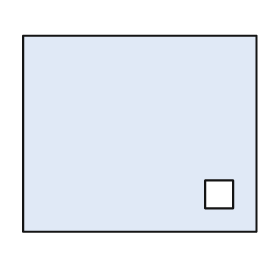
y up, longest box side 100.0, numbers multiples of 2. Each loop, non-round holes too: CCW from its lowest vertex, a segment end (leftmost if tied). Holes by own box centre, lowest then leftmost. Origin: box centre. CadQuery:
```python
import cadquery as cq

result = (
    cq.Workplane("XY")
    .moveTo(-50.0, -42.0)
    .lineTo(50.0, -42.0)
    .lineTo(50.0, 42.0)
    .lineTo(-50.0, 42.0)
    .close()
    .moveTo(28.0, -32.0)
    .lineTo(40.0, -32.0)
    .lineTo(40.0, -20.0)
    .lineTo(28.0, -20.0)
    .close()
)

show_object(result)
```